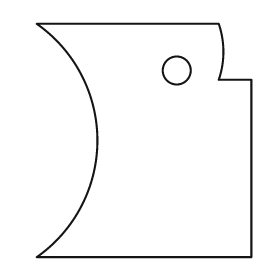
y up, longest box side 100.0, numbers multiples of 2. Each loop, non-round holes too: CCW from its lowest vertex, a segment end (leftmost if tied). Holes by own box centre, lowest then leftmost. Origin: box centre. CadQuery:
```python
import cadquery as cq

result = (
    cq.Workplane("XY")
    .moveTo(-46.0, -50.0)
    .lineTo(46.0, -50.0)
    .lineTo(46.0, 26.0)
    .lineTo(32.0, 26.0)
    .threePointArc((34.0, 38.0), (32.0, 50.0))
    .lineTo(-46.0, 50.0)
    .threePointArc((-20.0, 0.0), (-46.0, -50.0))
    .close()
    .moveTo(14.0, 30.0)
    .circle(6.0)
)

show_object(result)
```